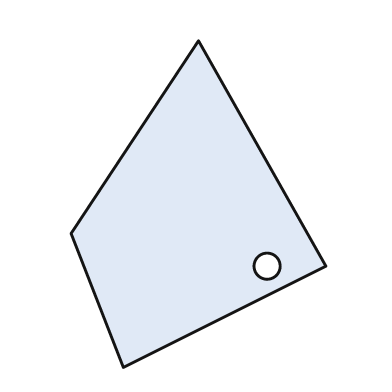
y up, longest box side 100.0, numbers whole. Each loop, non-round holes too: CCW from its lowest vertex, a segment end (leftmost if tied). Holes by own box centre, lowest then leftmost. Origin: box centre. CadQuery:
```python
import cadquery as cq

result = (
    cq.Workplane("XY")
    .moveTo(-23.0, -50.0)
    .lineTo(39.0, -19.0)
    .lineTo(0.0, 50.0)
    .lineTo(-39.0, -9.0)
    .close()
    .moveTo(21.0, -19.0)
    .circle(4.0)
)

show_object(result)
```